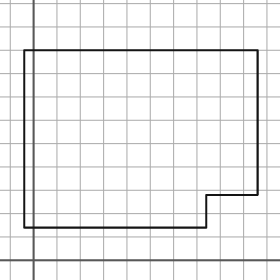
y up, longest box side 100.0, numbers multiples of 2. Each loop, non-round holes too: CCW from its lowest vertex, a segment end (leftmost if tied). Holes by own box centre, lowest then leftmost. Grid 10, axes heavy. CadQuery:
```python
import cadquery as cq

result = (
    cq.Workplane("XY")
    .moveTo(-4.0, 14.0)
    .lineTo(74.0, 14.0)
    .lineTo(74.0, 28.0)
    .lineTo(96.0, 28.0)
    .lineTo(96.0, 90.0)
    .lineTo(-4.0, 90.0)
    .close()
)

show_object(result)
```